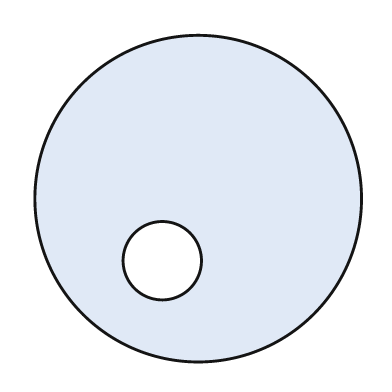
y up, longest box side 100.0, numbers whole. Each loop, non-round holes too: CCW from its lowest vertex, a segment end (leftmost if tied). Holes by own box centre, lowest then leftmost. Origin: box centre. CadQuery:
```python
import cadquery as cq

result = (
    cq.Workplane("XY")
    .moveTo(0.0, 0.0)
    .circle(50.0)
    .moveTo(-11.0, -19.0)
    .circle(12.0)
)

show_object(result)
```